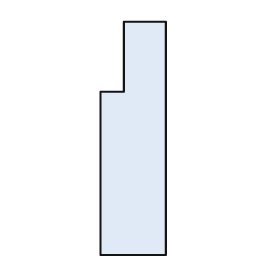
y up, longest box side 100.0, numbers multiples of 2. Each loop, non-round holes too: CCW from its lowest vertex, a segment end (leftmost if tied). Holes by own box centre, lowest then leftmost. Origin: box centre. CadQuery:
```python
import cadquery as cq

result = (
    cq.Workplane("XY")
    .moveTo(-14.0, -50.0)
    .lineTo(14.0, -50.0)
    .lineTo(14.0, 50.0)
    .lineTo(-4.0, 50.0)
    .lineTo(-4.0, 20.0)
    .lineTo(-14.0, 20.0)
    .close()
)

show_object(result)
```